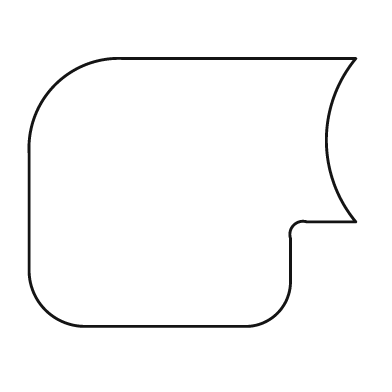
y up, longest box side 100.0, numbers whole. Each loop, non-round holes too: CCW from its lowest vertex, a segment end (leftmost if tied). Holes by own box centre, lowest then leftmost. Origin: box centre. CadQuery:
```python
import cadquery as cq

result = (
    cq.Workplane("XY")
    .moveTo(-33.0, -41.0)
    .lineTo(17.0, -41.0)
    .threePointArc((26.0, -37.0), (30.0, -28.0))
    .lineTo(30.0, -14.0)
    .threePointArc((31.0, -10.0), (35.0, -9.0))
    .lineTo(50.0, -9.0)
    .threePointArc((41.0, 16.0), (50.0, 41.0))
    .lineTo(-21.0, 41.0)
    .threePointArc((-42.0, 33.0), (-50.0, 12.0))
    .lineTo(-50.0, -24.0)
    .threePointArc((-45.0, -36.0), (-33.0, -41.0))
    .close()
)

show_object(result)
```